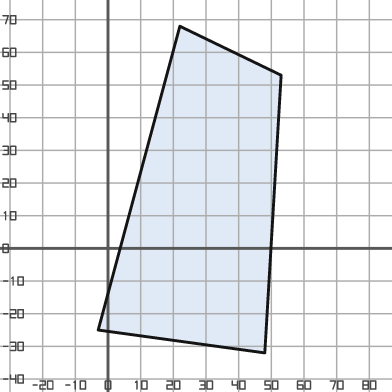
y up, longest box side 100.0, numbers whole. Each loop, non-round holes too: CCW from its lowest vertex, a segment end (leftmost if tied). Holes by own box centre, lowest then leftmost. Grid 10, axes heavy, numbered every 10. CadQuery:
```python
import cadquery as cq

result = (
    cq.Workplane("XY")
    .moveTo(48.0, -32.0)
    .lineTo(53.0, 53.0)
    .lineTo(22.0, 68.0)
    .lineTo(-3.0, -25.0)
    .close()
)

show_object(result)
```